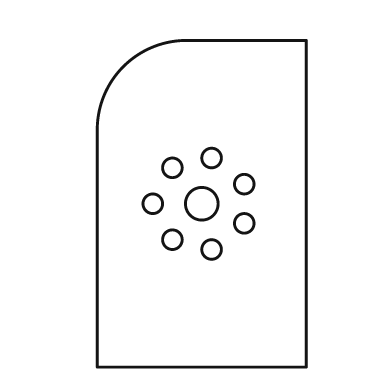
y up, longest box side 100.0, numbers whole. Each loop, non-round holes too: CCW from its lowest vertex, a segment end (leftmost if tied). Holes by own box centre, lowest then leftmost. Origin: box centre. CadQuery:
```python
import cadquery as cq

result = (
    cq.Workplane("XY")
    .moveTo(-32.0, -50.0)
    .lineTo(32.0, -50.0)
    .lineTo(32.0, 50.0)
    .lineTo(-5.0, 50.0)
    .threePointArc((-24.0, 42.0), (-32.0, 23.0))
    .close()
    .moveTo(3.0, -14.0)
    .circle(3.0)
    .moveTo(-9.0, -11.0)
    .circle(3.0)
    .moveTo(13.0, -6.0)
    .circle(3.0)
    .moveTo(-15.0, 0.0)
    .circle(3.0)
    .moveTo(0.0, 0.0)
    .circle(5.0)
    .moveTo(13.0, 6.0)
    .circle(3.0)
    .moveTo(-9.0, 11.0)
    .circle(3.0)
    .moveTo(3.0, 14.0)
    .circle(3.0)
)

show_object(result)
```